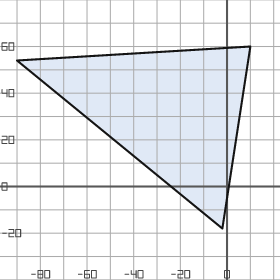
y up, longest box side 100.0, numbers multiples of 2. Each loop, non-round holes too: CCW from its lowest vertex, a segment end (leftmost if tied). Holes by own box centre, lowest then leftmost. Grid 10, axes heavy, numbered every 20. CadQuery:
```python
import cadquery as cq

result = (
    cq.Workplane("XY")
    .moveTo(-2.0, -18.0)
    .lineTo(10.0, 60.0)
    .lineTo(-90.0, 54.0)
    .close()
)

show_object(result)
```